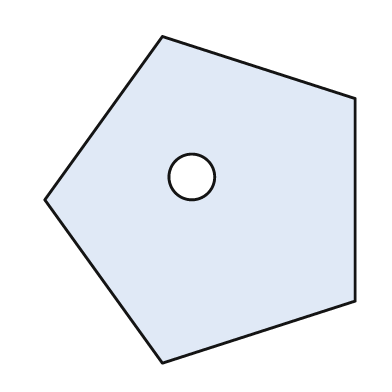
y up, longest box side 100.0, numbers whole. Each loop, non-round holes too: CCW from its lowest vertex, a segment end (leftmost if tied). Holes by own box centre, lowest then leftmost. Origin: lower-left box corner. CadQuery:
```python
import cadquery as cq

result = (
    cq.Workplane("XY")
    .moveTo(36.0, 0.0)
    .lineTo(95.0, 19.0)
    .lineTo(95.0, 81.0)
    .lineTo(36.0, 100.0)
    .lineTo(0.0, 50.0)
    .close()
    .moveTo(45.0, 57.0)
    .circle(7.0)
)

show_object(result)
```